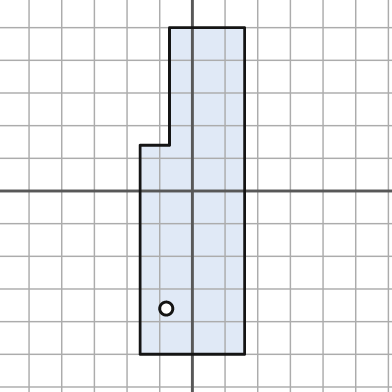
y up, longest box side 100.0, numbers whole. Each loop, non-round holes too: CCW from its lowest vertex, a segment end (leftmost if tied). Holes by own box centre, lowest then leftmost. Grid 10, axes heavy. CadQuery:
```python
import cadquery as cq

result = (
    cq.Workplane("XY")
    .moveTo(-16.0, -50.0)
    .lineTo(16.0, -50.0)
    .lineTo(16.0, 50.0)
    .lineTo(-7.0, 50.0)
    .lineTo(-7.0, 14.0)
    .lineTo(-16.0, 14.0)
    .close()
    .moveTo(-8.0, -36.0)
    .circle(2.0)
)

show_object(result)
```